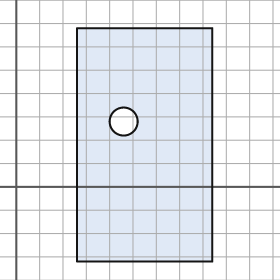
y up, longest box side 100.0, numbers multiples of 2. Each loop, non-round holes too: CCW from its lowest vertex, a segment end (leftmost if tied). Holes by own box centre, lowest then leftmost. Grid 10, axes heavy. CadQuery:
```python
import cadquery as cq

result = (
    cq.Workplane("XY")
    .moveTo(26.0, -32.0)
    .lineTo(84.0, -32.0)
    .lineTo(84.0, 68.0)
    .lineTo(26.0, 68.0)
    .close()
    .moveTo(46.0, 28.0)
    .circle(6.0)
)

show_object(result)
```